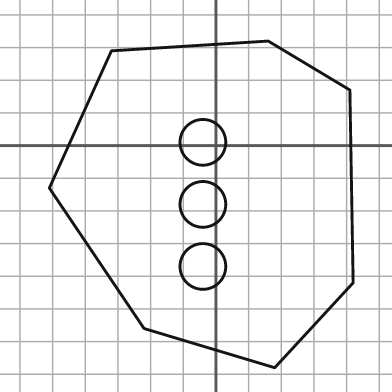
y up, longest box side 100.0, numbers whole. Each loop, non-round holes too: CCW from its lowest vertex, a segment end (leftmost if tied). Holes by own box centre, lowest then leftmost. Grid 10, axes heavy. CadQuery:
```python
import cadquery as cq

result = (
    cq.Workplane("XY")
    .moveTo(18.0, -68.0)
    .lineTo(42.0, -42.0)
    .lineTo(41.0, 17.0)
    .lineTo(16.0, 32.0)
    .lineTo(-32.0, 29.0)
    .lineTo(-51.0, -13.0)
    .lineTo(-22.0, -56.0)
    .close()
    .moveTo(-4.0, -37.0)
    .circle(7.0)
    .moveTo(-4.0, -18.0)
    .circle(7.0)
    .moveTo(-4.0, 1.0)
    .circle(7.0)
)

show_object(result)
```